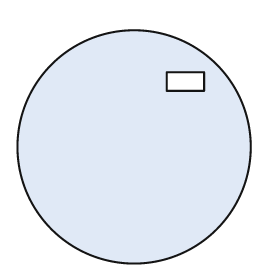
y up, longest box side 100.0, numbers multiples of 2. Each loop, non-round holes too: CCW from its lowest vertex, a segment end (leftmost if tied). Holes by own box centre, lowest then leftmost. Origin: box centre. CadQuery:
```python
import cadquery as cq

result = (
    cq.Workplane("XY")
    .moveTo(0.0, 0.0)
    .circle(50.0)
    .moveTo(14.0, 24.0)
    .lineTo(30.0, 24.0)
    .lineTo(30.0, 32.0)
    .lineTo(14.0, 32.0)
    .close()
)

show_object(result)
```